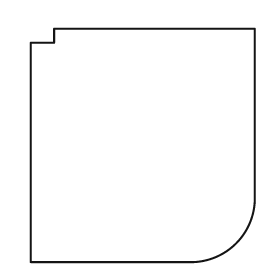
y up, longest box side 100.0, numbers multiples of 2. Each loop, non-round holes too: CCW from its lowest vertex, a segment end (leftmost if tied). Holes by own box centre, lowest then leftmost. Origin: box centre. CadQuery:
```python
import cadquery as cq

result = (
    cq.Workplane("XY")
    .moveTo(-48.0, -50.0)
    .lineTo(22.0, -50.0)
    .threePointArc((40.0, -42.0), (48.0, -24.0))
    .lineTo(48.0, 50.0)
    .lineTo(-38.0, 50.0)
    .lineTo(-38.0, 44.0)
    .lineTo(-48.0, 44.0)
    .close()
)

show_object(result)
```